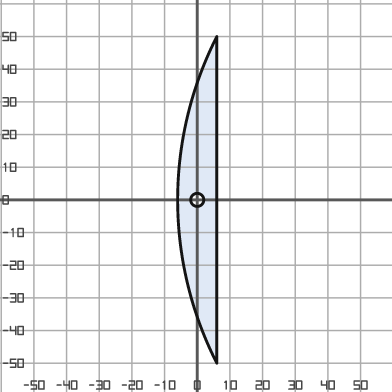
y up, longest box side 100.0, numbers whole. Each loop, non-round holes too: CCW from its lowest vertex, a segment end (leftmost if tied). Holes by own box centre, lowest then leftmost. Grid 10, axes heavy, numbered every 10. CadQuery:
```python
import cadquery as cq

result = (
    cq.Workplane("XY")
    .moveTo(6.0, -50.0)
    .lineTo(6.0, 50.0)
    .threePointArc((-6.0, 0.0), (6.0, -50.0))
    .close()
    .moveTo(0.0, 0.0)
    .circle(2.0)
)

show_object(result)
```